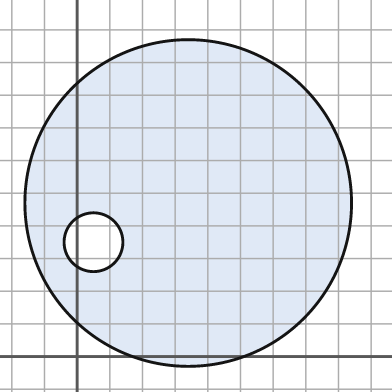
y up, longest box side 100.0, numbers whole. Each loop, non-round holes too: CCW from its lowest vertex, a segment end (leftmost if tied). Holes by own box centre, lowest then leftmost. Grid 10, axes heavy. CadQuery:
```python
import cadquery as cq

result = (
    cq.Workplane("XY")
    .moveTo(34.0, 47.0)
    .circle(50.0)
    .moveTo(5.0, 35.0)
    .circle(9.0)
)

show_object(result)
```